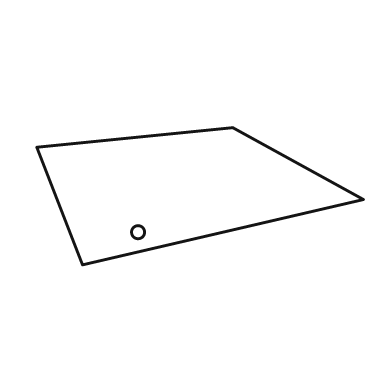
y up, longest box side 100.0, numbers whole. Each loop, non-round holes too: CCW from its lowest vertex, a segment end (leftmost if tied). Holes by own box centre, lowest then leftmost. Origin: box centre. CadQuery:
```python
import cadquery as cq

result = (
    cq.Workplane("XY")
    .moveTo(-36.0, -21.0)
    .lineTo(50.0, -1.0)
    .lineTo(10.0, 21.0)
    .lineTo(-50.0, 15.0)
    .close()
    .moveTo(-19.0, -11.0)
    .circle(2.0)
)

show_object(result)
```